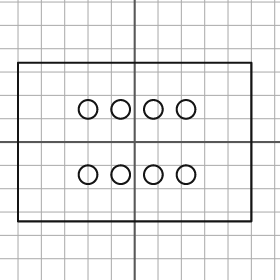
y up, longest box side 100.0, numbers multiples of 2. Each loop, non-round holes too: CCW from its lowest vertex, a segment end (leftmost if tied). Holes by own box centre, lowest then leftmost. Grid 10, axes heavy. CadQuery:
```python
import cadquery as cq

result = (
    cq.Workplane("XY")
    .moveTo(-50.0, -34.0)
    .lineTo(50.0, -34.0)
    .lineTo(50.0, 34.0)
    .lineTo(-50.0, 34.0)
    .close()
    .moveTo(-20.0, -14.0)
    .circle(4.0)
    .moveTo(-6.0, -14.0)
    .circle(4.0)
    .moveTo(8.0, -14.0)
    .circle(4.0)
    .moveTo(22.0, -14.0)
    .circle(4.0)
    .moveTo(-20.0, 14.0)
    .circle(4.0)
    .moveTo(-6.0, 14.0)
    .circle(4.0)
    .moveTo(8.0, 14.0)
    .circle(4.0)
    .moveTo(22.0, 14.0)
    .circle(4.0)
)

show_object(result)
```